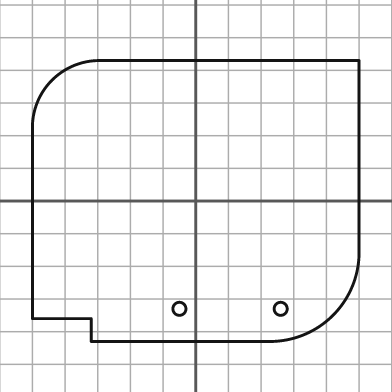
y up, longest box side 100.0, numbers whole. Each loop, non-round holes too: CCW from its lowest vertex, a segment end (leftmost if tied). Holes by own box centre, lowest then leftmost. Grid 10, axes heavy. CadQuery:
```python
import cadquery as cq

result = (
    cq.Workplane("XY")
    .moveTo(-32.0, -43.0)
    .lineTo(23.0, -43.0)
    .threePointArc((42.0, -35.0), (50.0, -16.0))
    .lineTo(50.0, 43.0)
    .lineTo(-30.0, 43.0)
    .threePointArc((-44.0, 37.0), (-50.0, 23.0))
    .lineTo(-50.0, -36.0)
    .lineTo(-32.0, -36.0)
    .close()
    .moveTo(-5.0, -33.0)
    .circle(2.0)
    .moveTo(26.0, -33.0)
    .circle(2.0)
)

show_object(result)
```